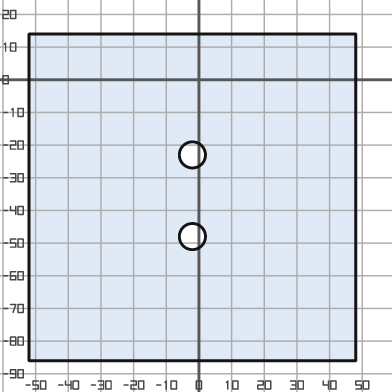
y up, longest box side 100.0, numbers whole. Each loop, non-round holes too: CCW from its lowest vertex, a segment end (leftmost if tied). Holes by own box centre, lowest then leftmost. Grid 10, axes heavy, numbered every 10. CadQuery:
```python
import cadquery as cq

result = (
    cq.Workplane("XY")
    .moveTo(-52.0, -86.0)
    .lineTo(48.0, -86.0)
    .lineTo(48.0, 14.0)
    .lineTo(-52.0, 14.0)
    .close()
    .moveTo(-2.0, -48.0)
    .circle(4.0)
    .moveTo(-2.0, -23.0)
    .circle(4.0)
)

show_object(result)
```